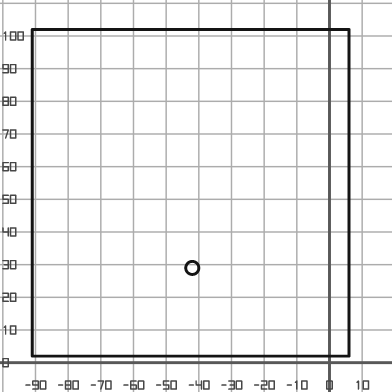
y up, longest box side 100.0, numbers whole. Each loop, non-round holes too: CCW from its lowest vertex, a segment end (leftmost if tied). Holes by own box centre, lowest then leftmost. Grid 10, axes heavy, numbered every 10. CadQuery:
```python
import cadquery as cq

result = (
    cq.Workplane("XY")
    .moveTo(-91.0, 2.0)
    .lineTo(6.0, 2.0)
    .lineTo(6.0, 102.0)
    .lineTo(-91.0, 102.0)
    .close()
    .moveTo(-42.0, 29.0)
    .circle(2.0)
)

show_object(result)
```